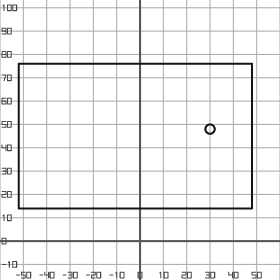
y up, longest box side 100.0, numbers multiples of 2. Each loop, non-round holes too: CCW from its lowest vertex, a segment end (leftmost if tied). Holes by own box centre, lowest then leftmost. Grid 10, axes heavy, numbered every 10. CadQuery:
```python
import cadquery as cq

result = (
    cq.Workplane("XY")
    .moveTo(-52.0, 14.0)
    .lineTo(48.0, 14.0)
    .lineTo(48.0, 76.0)
    .lineTo(-52.0, 76.0)
    .close()
    .moveTo(30.0, 48.0)
    .circle(2.0)
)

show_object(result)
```